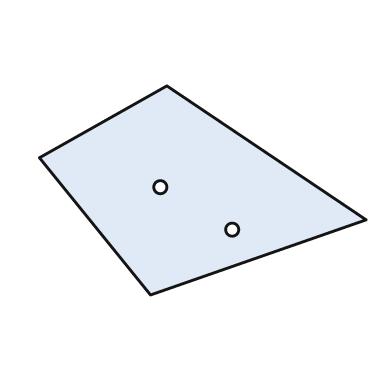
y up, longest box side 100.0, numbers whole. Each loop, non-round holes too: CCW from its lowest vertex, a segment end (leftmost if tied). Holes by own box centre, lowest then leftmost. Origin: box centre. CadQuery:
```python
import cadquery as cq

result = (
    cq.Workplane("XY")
    .moveTo(-16.0, -32.0)
    .lineTo(50.0, -9.0)
    .lineTo(-11.0, 32.0)
    .lineTo(-50.0, 10.0)
    .close()
    .moveTo(9.0, -12.0)
    .circle(2.0)
    .moveTo(-13.0, 1.0)
    .circle(2.0)
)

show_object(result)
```